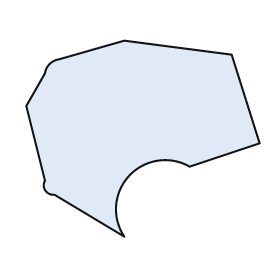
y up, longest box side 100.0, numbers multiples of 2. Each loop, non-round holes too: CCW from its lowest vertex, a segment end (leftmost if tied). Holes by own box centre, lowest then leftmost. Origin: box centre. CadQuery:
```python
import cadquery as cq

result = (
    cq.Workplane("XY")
    .moveTo(-8.0, -42.0)
    .threePointArc((-6.0, -16.0), (20.0, -12.0))
    .lineTo(50.0, -2.0)
    .lineTo(38.0, 36.0)
    .lineTo(-8.0, 42.0)
    .lineTo(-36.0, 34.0)
    .threePointArc((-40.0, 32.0), (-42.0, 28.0))
    .lineTo(-50.0, 14.0)
    .lineTo(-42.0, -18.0)
    .threePointArc((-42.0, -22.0), (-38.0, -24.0))
    .close()
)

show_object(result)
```